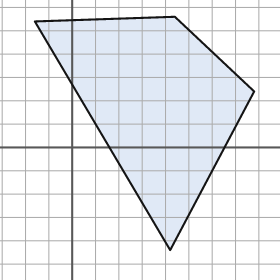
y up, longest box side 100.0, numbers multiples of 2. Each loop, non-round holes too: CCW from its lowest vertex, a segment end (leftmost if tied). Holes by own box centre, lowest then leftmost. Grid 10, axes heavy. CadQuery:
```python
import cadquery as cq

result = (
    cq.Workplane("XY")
    .moveTo(42.0, -44.0)
    .lineTo(78.0, 24.0)
    .lineTo(44.0, 56.0)
    .lineTo(-16.0, 54.0)
    .close()
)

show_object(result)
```